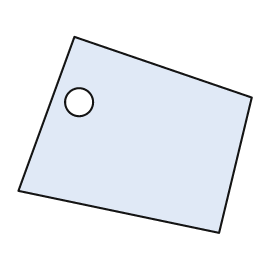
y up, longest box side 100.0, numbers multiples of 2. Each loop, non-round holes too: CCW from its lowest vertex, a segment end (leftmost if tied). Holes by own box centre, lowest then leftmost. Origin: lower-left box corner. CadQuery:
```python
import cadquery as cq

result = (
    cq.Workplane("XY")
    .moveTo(86.0, 0.0)
    .lineTo(100.0, 58.0)
    .lineTo(24.0, 84.0)
    .lineTo(0.0, 18.0)
    .close()
    .moveTo(26.0, 56.0)
    .circle(6.0)
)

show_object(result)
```